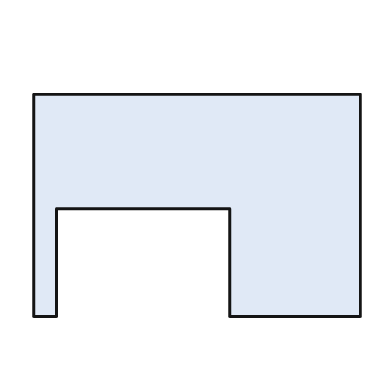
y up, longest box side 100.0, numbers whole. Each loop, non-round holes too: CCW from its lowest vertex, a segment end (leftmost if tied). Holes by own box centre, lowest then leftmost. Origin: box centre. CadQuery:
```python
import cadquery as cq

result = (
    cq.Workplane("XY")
    .moveTo(-50.0, -34.0)
    .lineTo(-43.0, -34.0)
    .lineTo(-43.0, -1.0)
    .lineTo(10.0, -1.0)
    .lineTo(10.0, -34.0)
    .lineTo(50.0, -34.0)
    .lineTo(50.0, 34.0)
    .lineTo(-50.0, 34.0)
    .close()
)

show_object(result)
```